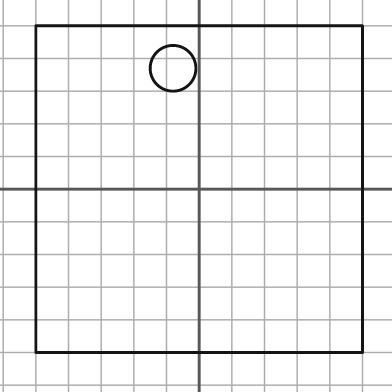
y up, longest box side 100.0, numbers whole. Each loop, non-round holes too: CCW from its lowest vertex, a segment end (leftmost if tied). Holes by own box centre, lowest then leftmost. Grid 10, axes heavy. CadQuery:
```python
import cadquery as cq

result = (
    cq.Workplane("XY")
    .moveTo(-50.0, -50.0)
    .lineTo(50.0, -50.0)
    .lineTo(50.0, 50.0)
    .lineTo(-50.0, 50.0)
    .close()
    .moveTo(-8.0, 37.0)
    .circle(7.0)
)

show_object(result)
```